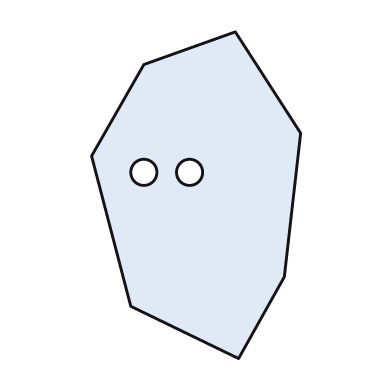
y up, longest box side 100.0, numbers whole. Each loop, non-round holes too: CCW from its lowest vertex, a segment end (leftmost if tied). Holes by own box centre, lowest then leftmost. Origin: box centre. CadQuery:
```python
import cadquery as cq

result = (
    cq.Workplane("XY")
    .moveTo(13.0, -50.0)
    .lineTo(27.0, -25.0)
    .lineTo(32.0, 19.0)
    .lineTo(12.0, 50.0)
    .lineTo(-16.0, 40.0)
    .lineTo(-32.0, 12.0)
    .lineTo(-20.0, -34.0)
    .close()
    .moveTo(-16.0, 7.0)
    .circle(4.0)
    .moveTo(-2.0, 7.0)
    .circle(4.0)
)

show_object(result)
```